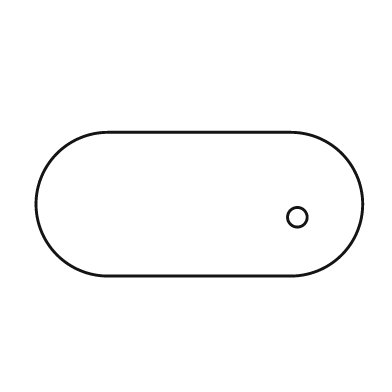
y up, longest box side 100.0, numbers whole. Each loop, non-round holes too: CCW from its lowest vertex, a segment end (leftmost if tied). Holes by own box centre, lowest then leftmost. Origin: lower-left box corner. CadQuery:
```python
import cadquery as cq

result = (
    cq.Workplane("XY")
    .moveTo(22.0, 0.0)
    .lineTo(78.0, 0.0)
    .threePointArc((100.0, 22.0), (78.0, 44.0))
    .lineTo(22.0, 44.0)
    .threePointArc((0.0, 22.0), (22.0, 0.0))
    .close()
    .moveTo(80.0, 18.0)
    .circle(3.0)
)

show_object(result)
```